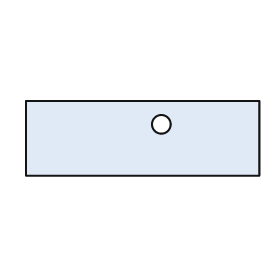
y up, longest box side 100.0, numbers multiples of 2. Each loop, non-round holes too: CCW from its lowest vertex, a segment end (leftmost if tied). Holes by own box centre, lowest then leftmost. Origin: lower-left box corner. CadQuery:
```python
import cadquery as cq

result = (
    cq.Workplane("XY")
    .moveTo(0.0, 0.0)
    .lineTo(100.0, 0.0)
    .lineTo(100.0, 32.0)
    .lineTo(0.0, 32.0)
    .close()
    .moveTo(58.0, 22.0)
    .circle(4.0)
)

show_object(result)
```